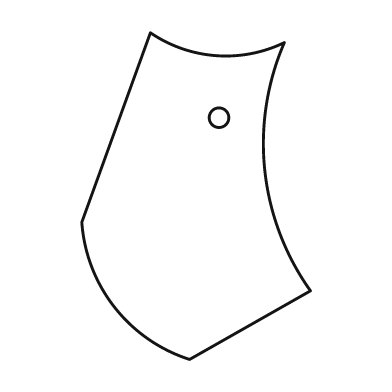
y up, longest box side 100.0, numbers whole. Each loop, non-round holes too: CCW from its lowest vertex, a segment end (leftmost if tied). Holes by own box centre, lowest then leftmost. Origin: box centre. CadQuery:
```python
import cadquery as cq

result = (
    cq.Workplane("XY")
    .moveTo(-2.0, -50.0)
    .lineTo(35.0, -29.0)
    .threePointArc((21.0, 8.0), (27.0, 47.0))
    .threePointArc((6.0, 43.0), (-14.0, 50.0))
    .lineTo(-35.0, -8.0)
    .threePointArc((-25.0, -34.0), (-2.0, -50.0))
    .close()
    .moveTo(7.0, 24.0)
    .circle(3.0)
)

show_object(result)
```